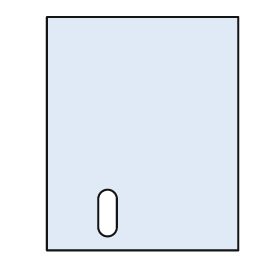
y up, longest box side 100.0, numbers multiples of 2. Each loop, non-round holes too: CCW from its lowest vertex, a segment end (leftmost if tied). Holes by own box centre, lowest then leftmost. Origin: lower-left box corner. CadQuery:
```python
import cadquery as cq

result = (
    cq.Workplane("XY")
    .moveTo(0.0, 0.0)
    .lineTo(82.0, 0.0)
    .lineTo(82.0, 100.0)
    .lineTo(0.0, 100.0)
    .close()
    .moveTo(22.0, 10.0)
    .threePointArc((26.0, 6.0), (30.0, 10.0))
    .lineTo(30.0, 22.0)
    .threePointArc((26.0, 26.0), (22.0, 22.0))
    .close()
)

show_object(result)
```